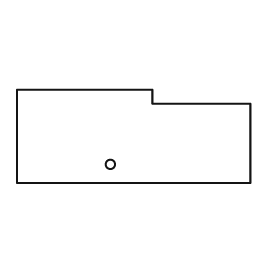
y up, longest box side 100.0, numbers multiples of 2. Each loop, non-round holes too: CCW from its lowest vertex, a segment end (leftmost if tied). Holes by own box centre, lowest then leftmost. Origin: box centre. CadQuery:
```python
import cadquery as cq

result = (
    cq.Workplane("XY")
    .moveTo(-50.0, -20.0)
    .lineTo(50.0, -20.0)
    .lineTo(50.0, 14.0)
    .lineTo(8.0, 14.0)
    .lineTo(8.0, 20.0)
    .lineTo(-50.0, 20.0)
    .close()
    .moveTo(-10.0, -12.0)
    .circle(2.0)
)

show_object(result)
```